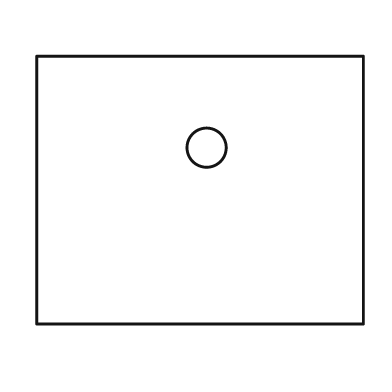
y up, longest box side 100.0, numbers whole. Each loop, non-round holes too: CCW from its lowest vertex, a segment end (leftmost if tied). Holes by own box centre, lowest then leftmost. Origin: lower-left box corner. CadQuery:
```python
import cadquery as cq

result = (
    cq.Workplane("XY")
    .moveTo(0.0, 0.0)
    .lineTo(100.0, 0.0)
    .lineTo(100.0, 82.0)
    .lineTo(0.0, 82.0)
    .close()
    .moveTo(52.0, 54.0)
    .circle(6.0)
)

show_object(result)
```